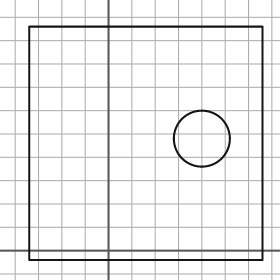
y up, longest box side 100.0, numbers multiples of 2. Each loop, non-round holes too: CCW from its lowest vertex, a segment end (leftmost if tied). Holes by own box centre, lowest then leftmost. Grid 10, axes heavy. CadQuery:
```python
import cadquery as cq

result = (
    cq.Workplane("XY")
    .moveTo(-34.0, -4.0)
    .lineTo(66.0, -4.0)
    .lineTo(66.0, 96.0)
    .lineTo(-34.0, 96.0)
    .close()
    .moveTo(40.0, 48.0)
    .circle(12.0)
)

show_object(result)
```